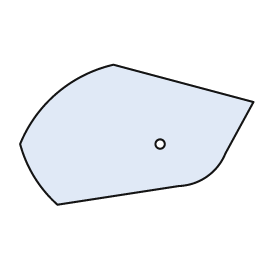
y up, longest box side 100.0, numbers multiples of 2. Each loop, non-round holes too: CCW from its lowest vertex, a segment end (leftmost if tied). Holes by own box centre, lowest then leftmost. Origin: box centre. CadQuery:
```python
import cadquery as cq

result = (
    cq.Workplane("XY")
    .moveTo(-34.0, -30.0)
    .lineTo(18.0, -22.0)
    .threePointArc((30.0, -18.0), (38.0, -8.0))
    .lineTo(50.0, 14.0)
    .lineTo(-10.0, 30.0)
    .threePointArc((-34.0, 18.0), (-50.0, -4.0))
    .threePointArc((-44.0, -18.0), (-34.0, -30.0))
    .close()
    .moveTo(10.0, -4.0)
    .circle(2.0)
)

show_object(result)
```